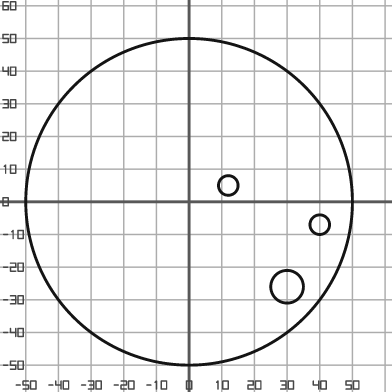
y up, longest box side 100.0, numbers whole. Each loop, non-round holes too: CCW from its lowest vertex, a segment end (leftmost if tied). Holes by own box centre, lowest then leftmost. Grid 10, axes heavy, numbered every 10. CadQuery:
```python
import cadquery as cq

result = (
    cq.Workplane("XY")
    .moveTo(0.0, 0.0)
    .circle(50.0)
    .moveTo(30.0, -26.0)
    .circle(5.0)
    .moveTo(40.0, -7.0)
    .circle(3.0)
    .moveTo(12.0, 5.0)
    .circle(3.0)
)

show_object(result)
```